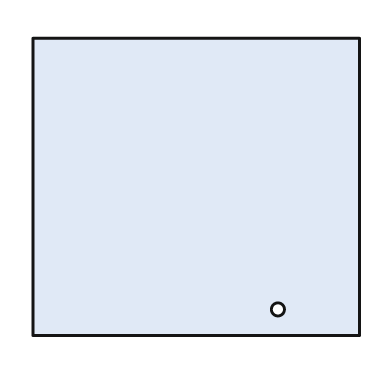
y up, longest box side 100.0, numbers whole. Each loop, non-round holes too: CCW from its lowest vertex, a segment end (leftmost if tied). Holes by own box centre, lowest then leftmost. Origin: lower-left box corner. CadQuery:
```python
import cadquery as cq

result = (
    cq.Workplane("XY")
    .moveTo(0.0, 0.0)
    .lineTo(100.0, 0.0)
    .lineTo(100.0, 91.0)
    .lineTo(0.0, 91.0)
    .close()
    .moveTo(75.0, 8.0)
    .circle(2.0)
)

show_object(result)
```